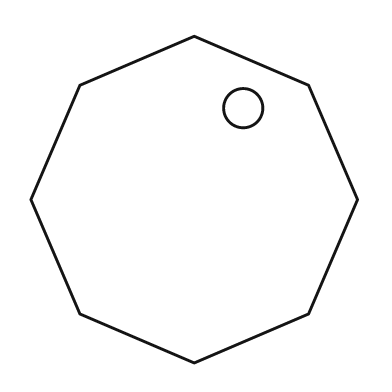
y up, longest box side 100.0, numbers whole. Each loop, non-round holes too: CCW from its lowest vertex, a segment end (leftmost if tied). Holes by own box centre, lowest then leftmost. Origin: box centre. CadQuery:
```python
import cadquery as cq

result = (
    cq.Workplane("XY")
    .moveTo(0.0, -50.0)
    .lineTo(35.0, -35.0)
    .lineTo(50.0, 0.0)
    .lineTo(35.0, 35.0)
    .lineTo(0.0, 50.0)
    .lineTo(-35.0, 35.0)
    .lineTo(-50.0, 0.0)
    .lineTo(-35.0, -35.0)
    .close()
    .moveTo(15.0, 28.0)
    .circle(6.0)
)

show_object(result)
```